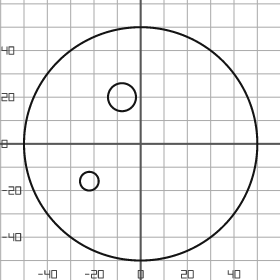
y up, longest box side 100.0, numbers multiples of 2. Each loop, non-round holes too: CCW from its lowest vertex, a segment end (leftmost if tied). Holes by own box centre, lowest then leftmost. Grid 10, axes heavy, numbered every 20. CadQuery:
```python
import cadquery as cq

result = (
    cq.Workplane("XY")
    .moveTo(0.0, 0.0)
    .circle(50.0)
    .moveTo(-22.0, -16.0)
    .circle(4.0)
    .moveTo(-8.0, 20.0)
    .circle(6.0)
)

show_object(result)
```